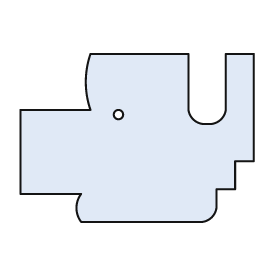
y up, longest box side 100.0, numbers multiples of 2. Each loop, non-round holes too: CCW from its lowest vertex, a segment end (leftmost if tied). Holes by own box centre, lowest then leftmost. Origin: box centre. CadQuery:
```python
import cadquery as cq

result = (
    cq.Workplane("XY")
    .moveTo(-24.0, -36.0)
    .lineTo(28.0, -36.0)
    .threePointArc((32.0, -34.0), (34.0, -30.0))
    .lineTo(34.0, -22.0)
    .lineTo(42.0, -22.0)
    .lineTo(42.0, -10.0)
    .lineTo(50.0, -10.0)
    .lineTo(50.0, 36.0)
    .lineTo(38.0, 36.0)
    .lineTo(38.0, 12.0)
    .threePointArc((36.0, 8.0), (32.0, 6.0))
    .lineTo(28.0, 6.0)
    .threePointArc((24.0, 8.0), (22.0, 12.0))
    .lineTo(22.0, 36.0)
    .lineTo(-20.0, 36.0)
    .threePointArc((-22.0, 24.0), (-20.0, 12.0))
    .lineTo(-50.0, 12.0)
    .lineTo(-50.0, -24.0)
    .lineTo(-24.0, -24.0)
    .threePointArc((-26.0, -30.0), (-24.0, -36.0))
    .close()
    .moveTo(-8.0, 10.0)
    .circle(2.0)
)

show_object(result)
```